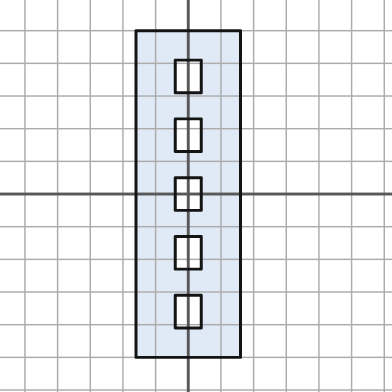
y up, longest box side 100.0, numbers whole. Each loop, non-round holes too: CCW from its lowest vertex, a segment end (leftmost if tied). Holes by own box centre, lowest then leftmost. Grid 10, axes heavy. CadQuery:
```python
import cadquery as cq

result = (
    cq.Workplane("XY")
    .moveTo(-16.0, -50.0)
    .lineTo(16.0, -50.0)
    .lineTo(16.0, 50.0)
    .lineTo(-16.0, 50.0)
    .close()
    .moveTo(-4.0, -41.0)
    .lineTo(4.0, -41.0)
    .lineTo(4.0, -31.0)
    .lineTo(-4.0, -31.0)
    .close()
    .moveTo(-4.0, -23.0)
    .lineTo(4.0, -23.0)
    .lineTo(4.0, -13.0)
    .lineTo(-4.0, -13.0)
    .close()
    .moveTo(-4.0, -5.0)
    .lineTo(4.0, -5.0)
    .lineTo(4.0, 5.0)
    .lineTo(-4.0, 5.0)
    .close()
    .moveTo(-4.0, 13.0)
    .lineTo(4.0, 13.0)
    .lineTo(4.0, 23.0)
    .lineTo(-4.0, 23.0)
    .close()
    .moveTo(-4.0, 31.0)
    .lineTo(4.0, 31.0)
    .lineTo(4.0, 41.0)
    .lineTo(-4.0, 41.0)
    .close()
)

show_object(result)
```